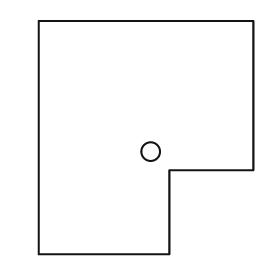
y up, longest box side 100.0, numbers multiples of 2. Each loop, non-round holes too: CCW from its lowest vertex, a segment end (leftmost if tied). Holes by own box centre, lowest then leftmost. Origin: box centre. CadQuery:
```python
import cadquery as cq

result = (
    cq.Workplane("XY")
    .moveTo(-46.0, -50.0)
    .lineTo(10.0, -50.0)
    .lineTo(10.0, -14.0)
    .lineTo(46.0, -14.0)
    .lineTo(46.0, 50.0)
    .lineTo(-46.0, 50.0)
    .close()
    .moveTo(2.0, -6.0)
    .circle(4.0)
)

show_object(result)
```